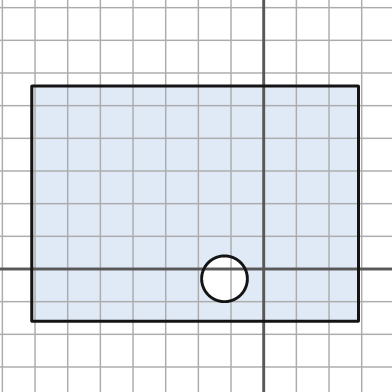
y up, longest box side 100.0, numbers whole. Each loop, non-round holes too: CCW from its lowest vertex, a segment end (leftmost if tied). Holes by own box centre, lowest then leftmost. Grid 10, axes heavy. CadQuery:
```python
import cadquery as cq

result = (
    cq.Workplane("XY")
    .moveTo(-71.0, -16.0)
    .lineTo(29.0, -16.0)
    .lineTo(29.0, 56.0)
    .lineTo(-71.0, 56.0)
    .close()
    .moveTo(-12.0, -3.0)
    .circle(7.0)
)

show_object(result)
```